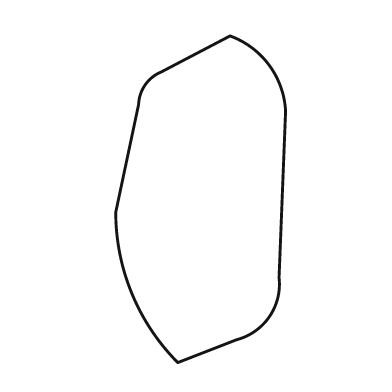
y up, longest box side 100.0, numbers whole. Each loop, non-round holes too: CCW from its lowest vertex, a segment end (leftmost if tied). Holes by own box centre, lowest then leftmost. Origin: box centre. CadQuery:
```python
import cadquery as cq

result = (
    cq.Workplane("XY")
    .moveTo(-7.0, -50.0)
    .lineTo(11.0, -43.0)
    .threePointArc((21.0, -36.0), (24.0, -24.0))
    .lineTo(26.0, 27.0)
    .threePointArc((21.0, 41.0), (9.0, 50.0))
    .lineTo(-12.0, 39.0)
    .threePointArc((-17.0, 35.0), (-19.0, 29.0))
    .lineTo(-26.0, -4.0)
    .threePointArc((-21.0, -29.0), (-7.0, -50.0))
    .close()
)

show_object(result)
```